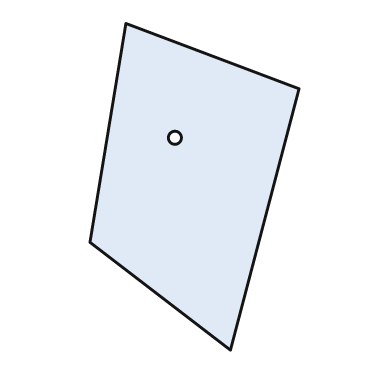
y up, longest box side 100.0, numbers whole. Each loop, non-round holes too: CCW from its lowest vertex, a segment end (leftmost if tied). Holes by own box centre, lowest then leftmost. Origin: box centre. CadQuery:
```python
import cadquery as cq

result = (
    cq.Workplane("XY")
    .moveTo(11.0, -50.0)
    .lineTo(32.0, 30.0)
    .lineTo(-21.0, 50.0)
    .lineTo(-32.0, -17.0)
    .close()
    .moveTo(-6.0, 15.0)
    .circle(2.0)
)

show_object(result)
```